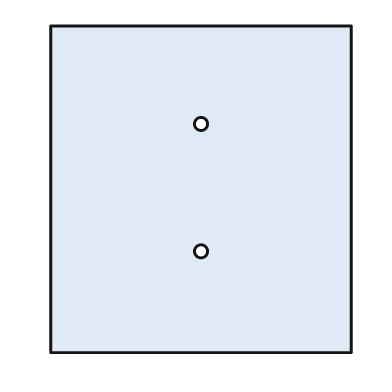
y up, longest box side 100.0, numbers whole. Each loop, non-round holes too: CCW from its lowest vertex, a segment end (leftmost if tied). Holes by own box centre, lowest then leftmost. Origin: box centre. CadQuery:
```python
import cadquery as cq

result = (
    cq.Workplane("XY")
    .moveTo(-46.0, -50.0)
    .lineTo(46.0, -50.0)
    .lineTo(46.0, 50.0)
    .lineTo(-46.0, 50.0)
    .close()
    .moveTo(0.0, -19.0)
    .circle(2.0)
    .moveTo(0.0, 20.0)
    .circle(2.0)
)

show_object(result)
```